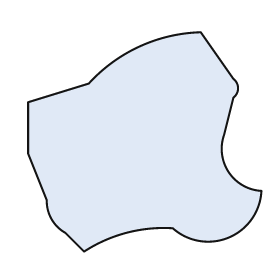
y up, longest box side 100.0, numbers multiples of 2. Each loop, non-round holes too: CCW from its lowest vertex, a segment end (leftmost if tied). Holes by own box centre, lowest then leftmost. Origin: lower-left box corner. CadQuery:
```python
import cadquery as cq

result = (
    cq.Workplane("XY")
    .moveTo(24.0, 0.0)
    .threePointArc((42.0, 8.0), (62.0, 10.0))
    .threePointArc((86.0, 6.0), (100.0, 26.0))
    .threePointArc((86.0, 34.0), (84.0, 50.0))
    .lineTo(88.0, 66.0)
    .threePointArc((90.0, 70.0), (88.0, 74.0))
    .lineTo(74.0, 94.0)
    .threePointArc((48.0, 88.0), (26.0, 72.0))
    .lineTo(0.0, 64.0)
    .lineTo(0.0, 42.0)
    .lineTo(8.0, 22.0)
    .threePointArc((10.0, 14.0), (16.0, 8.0))
    .close()
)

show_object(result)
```